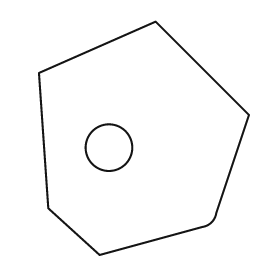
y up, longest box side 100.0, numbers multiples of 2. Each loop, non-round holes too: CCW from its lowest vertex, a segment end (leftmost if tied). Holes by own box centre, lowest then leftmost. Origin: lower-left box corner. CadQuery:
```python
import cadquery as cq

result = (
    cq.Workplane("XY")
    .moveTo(26.0, 0.0)
    .lineTo(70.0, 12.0)
    .threePointArc((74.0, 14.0), (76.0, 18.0))
    .lineTo(90.0, 60.0)
    .lineTo(50.0, 100.0)
    .lineTo(0.0, 78.0)
    .lineTo(4.0, 20.0)
    .close()
    .moveTo(30.0, 46.0)
    .circle(10.0)
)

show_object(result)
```